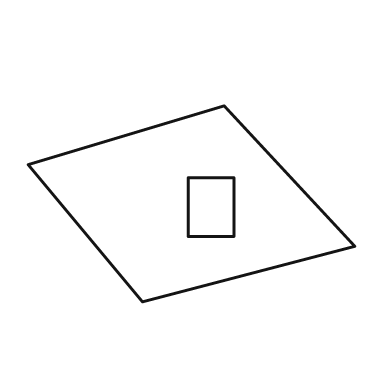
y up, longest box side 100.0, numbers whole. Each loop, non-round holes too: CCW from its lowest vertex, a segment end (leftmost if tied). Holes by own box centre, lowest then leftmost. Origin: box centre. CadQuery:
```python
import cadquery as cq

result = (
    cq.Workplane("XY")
    .moveTo(-15.0, -30.0)
    .lineTo(50.0, -13.0)
    .lineTo(10.0, 30.0)
    .lineTo(-50.0, 12.0)
    .close()
    .moveTo(-1.0, -10.0)
    .lineTo(13.0, -10.0)
    .lineTo(13.0, 8.0)
    .lineTo(-1.0, 8.0)
    .close()
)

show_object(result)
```